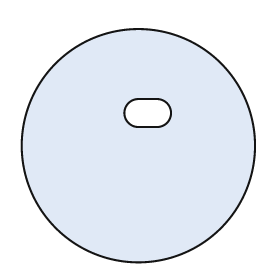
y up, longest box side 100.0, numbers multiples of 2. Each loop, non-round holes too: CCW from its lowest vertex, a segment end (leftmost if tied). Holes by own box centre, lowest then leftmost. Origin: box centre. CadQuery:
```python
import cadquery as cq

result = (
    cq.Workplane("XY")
    .moveTo(0.0, 0.0)
    .circle(50.0)
    .moveTo(0.0, 8.0)
    .lineTo(8.0, 8.0)
    .threePointArc((14.0, 14.0), (8.0, 20.0))
    .lineTo(0.0, 20.0)
    .threePointArc((-6.0, 14.0), (0.0, 8.0))
    .close()
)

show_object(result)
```